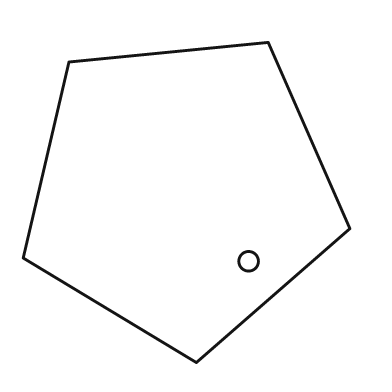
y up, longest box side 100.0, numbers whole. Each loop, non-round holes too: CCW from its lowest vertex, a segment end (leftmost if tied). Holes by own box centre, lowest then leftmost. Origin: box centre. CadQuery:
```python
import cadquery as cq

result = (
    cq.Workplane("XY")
    .moveTo(3.0, -49.0)
    .lineTo(50.0, -8.0)
    .lineTo(25.0, 49.0)
    .lineTo(-36.0, 43.0)
    .lineTo(-50.0, -17.0)
    .close()
    .moveTo(19.0, -18.0)
    .circle(3.0)
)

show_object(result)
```